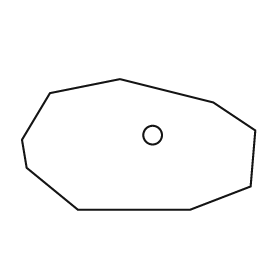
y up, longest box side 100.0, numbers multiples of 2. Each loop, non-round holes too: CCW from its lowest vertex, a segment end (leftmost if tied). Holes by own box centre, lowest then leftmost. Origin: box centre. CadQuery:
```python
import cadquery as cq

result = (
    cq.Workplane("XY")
    .moveTo(-26.0, -28.0)
    .lineTo(22.0, -28.0)
    .lineTo(48.0, -18.0)
    .lineTo(50.0, 6.0)
    .lineTo(32.0, 18.0)
    .lineTo(-8.0, 28.0)
    .lineTo(-38.0, 22.0)
    .lineTo(-50.0, 2.0)
    .lineTo(-48.0, -10.0)
    .close()
    .moveTo(6.0, 4.0)
    .circle(4.0)
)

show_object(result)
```